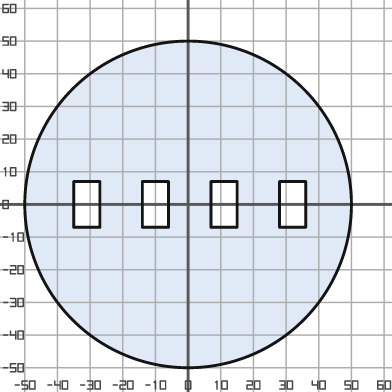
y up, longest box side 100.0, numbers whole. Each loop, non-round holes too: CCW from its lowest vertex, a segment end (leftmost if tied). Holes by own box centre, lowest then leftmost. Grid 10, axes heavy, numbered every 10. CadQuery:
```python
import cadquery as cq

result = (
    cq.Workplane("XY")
    .moveTo(0.0, 0.0)
    .circle(50.0)
    .moveTo(-35.0, -7.0)
    .lineTo(-27.0, -7.0)
    .lineTo(-27.0, 7.0)
    .lineTo(-35.0, 7.0)
    .close()
    .moveTo(-14.0, -7.0)
    .lineTo(-6.0, -7.0)
    .lineTo(-6.0, 7.0)
    .lineTo(-14.0, 7.0)
    .close()
    .moveTo(7.0, -7.0)
    .lineTo(15.0, -7.0)
    .lineTo(15.0, 7.0)
    .lineTo(7.0, 7.0)
    .close()
    .moveTo(28.0, -7.0)
    .lineTo(36.0, -7.0)
    .lineTo(36.0, 7.0)
    .lineTo(28.0, 7.0)
    .close()
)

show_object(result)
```